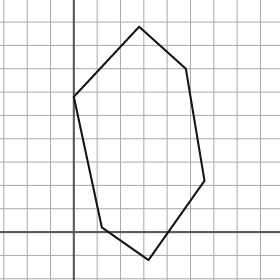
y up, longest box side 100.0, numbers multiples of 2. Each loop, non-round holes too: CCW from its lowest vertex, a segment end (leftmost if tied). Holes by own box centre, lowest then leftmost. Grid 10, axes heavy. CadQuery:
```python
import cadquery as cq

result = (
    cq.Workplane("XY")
    .moveTo(32.0, -12.0)
    .lineTo(56.0, 22.0)
    .lineTo(48.0, 70.0)
    .lineTo(28.0, 88.0)
    .lineTo(0.0, 58.0)
    .lineTo(12.0, 2.0)
    .close()
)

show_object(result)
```